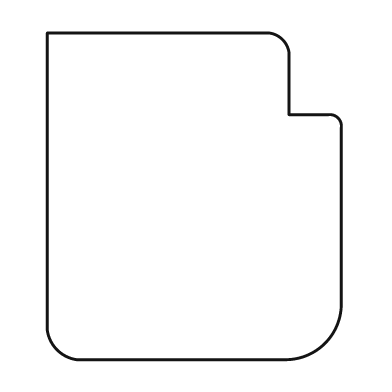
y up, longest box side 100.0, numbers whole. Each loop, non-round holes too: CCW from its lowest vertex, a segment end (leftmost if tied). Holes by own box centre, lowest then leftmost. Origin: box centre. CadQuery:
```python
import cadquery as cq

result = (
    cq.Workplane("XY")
    .moveTo(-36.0, -50.0)
    .lineTo(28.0, -50.0)
    .threePointArc((40.0, -45.0), (45.0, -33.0))
    .lineTo(45.0, 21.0)
    .threePointArc((44.0, 24.0), (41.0, 25.0))
    .lineTo(29.0, 25.0)
    .lineTo(29.0, 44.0)
    .threePointArc((27.0, 48.0), (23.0, 50.0))
    .lineTo(-45.0, 50.0)
    .lineTo(-45.0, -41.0)
    .threePointArc((-42.0, -47.0), (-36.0, -50.0))
    .close()
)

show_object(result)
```